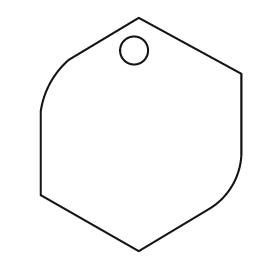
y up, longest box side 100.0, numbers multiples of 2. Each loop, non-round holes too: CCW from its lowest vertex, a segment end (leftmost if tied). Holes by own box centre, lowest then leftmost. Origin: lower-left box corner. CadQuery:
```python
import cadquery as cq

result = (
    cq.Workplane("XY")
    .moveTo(42.0, 0.0)
    .lineTo(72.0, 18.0)
    .threePointArc((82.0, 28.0), (86.0, 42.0))
    .lineTo(86.0, 76.0)
    .lineTo(42.0, 100.0)
    .lineTo(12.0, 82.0)
    .threePointArc((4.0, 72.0), (0.0, 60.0))
    .lineTo(0.0, 24.0)
    .close()
    .moveTo(40.0, 86.0)
    .circle(6.0)
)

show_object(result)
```